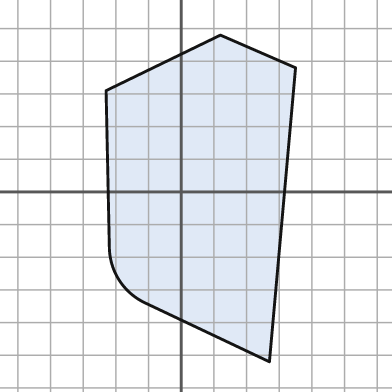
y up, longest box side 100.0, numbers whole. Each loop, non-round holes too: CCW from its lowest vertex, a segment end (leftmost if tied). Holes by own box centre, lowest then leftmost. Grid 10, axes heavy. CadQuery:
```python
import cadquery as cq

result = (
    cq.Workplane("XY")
    .moveTo(27.0, -52.0)
    .lineTo(35.0, 38.0)
    .lineTo(12.0, 48.0)
    .lineTo(-23.0, 31.0)
    .lineTo(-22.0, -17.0)
    .threePointArc((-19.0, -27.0), (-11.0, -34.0))
    .close()
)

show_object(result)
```